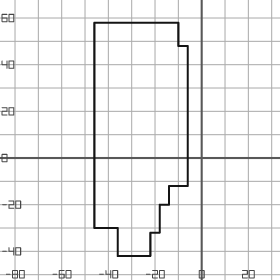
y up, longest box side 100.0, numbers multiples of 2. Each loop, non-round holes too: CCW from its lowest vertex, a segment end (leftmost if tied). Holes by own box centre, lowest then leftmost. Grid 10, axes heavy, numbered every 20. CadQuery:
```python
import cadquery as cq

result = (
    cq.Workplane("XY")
    .moveTo(-36.0, -42.0)
    .lineTo(-22.0, -42.0)
    .lineTo(-22.0, -32.0)
    .lineTo(-18.0, -32.0)
    .lineTo(-18.0, -20.0)
    .lineTo(-14.0, -20.0)
    .lineTo(-14.0, -12.0)
    .lineTo(-6.0, -12.0)
    .lineTo(-6.0, 48.0)
    .lineTo(-10.0, 48.0)
    .lineTo(-10.0, 58.0)
    .lineTo(-46.0, 58.0)
    .lineTo(-46.0, -30.0)
    .lineTo(-36.0, -30.0)
    .close()
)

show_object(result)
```